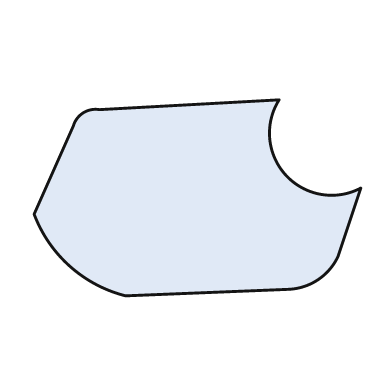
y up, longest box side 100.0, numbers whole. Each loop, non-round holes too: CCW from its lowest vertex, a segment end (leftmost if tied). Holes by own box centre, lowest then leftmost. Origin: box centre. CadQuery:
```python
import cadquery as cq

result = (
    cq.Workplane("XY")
    .moveTo(-22.0, -30.0)
    .lineTo(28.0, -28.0)
    .threePointArc((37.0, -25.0), (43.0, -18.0))
    .lineTo(50.0, 3.0)
    .threePointArc((27.0, 7.0), (25.0, 30.0))
    .lineTo(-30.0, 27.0)
    .threePointArc((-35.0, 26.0), (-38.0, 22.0))
    .lineTo(-50.0, -5.0)
    .threePointArc((-39.0, -21.0), (-22.0, -30.0))
    .close()
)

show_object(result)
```